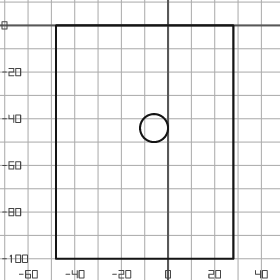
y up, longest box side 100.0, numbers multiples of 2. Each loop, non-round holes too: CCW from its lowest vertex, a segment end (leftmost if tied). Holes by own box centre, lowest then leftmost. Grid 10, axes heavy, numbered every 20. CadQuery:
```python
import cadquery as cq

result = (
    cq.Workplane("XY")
    .moveTo(-48.0, -100.0)
    .lineTo(28.0, -100.0)
    .lineTo(28.0, 0.0)
    .lineTo(-48.0, 0.0)
    .close()
    .moveTo(-6.0, -44.0)
    .circle(6.0)
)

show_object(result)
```